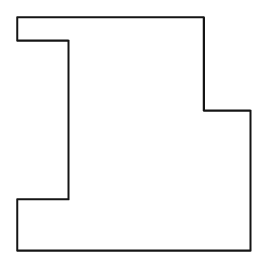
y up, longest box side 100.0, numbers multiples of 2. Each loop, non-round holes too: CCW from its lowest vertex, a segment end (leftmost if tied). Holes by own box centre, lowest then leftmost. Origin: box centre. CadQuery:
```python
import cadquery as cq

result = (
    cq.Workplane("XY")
    .moveTo(-50.0, -50.0)
    .lineTo(50.0, -50.0)
    .lineTo(50.0, 10.0)
    .lineTo(30.0, 10.0)
    .lineTo(30.0, 50.0)
    .lineTo(-50.0, 50.0)
    .lineTo(-50.0, 40.0)
    .lineTo(-28.0, 40.0)
    .lineTo(-28.0, -28.0)
    .lineTo(-50.0, -28.0)
    .close()
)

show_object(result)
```